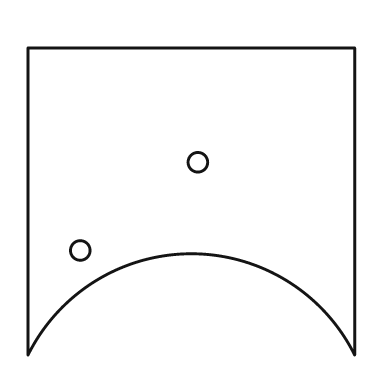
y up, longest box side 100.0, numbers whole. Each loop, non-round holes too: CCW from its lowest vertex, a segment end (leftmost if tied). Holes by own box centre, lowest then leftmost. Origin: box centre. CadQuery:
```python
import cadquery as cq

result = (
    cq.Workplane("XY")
    .moveTo(-50.0, -47.0)
    .threePointArc((0.0, -16.0), (50.0, -47.0))
    .lineTo(50.0, 47.0)
    .lineTo(-50.0, 47.0)
    .close()
    .moveTo(-34.0, -15.0)
    .circle(3.0)
    .moveTo(2.0, 12.0)
    .circle(3.0)
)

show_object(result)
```